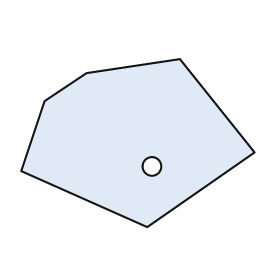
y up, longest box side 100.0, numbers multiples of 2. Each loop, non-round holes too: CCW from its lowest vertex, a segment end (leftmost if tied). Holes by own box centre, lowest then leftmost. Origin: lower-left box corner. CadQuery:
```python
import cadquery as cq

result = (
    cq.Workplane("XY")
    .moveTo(54.0, 0.0)
    .lineTo(100.0, 32.0)
    .lineTo(68.0, 72.0)
    .lineTo(28.0, 66.0)
    .lineTo(10.0, 54.0)
    .lineTo(0.0, 24.0)
    .close()
    .moveTo(56.0, 26.0)
    .circle(4.0)
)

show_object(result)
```